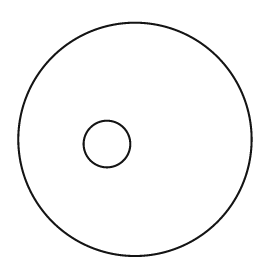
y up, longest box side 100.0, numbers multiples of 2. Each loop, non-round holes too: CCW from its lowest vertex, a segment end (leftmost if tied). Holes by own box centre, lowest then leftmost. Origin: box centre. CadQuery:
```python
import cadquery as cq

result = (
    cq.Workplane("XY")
    .moveTo(0.0, 0.0)
    .circle(50.0)
    .moveTo(-12.0, -2.0)
    .circle(10.0)
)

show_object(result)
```